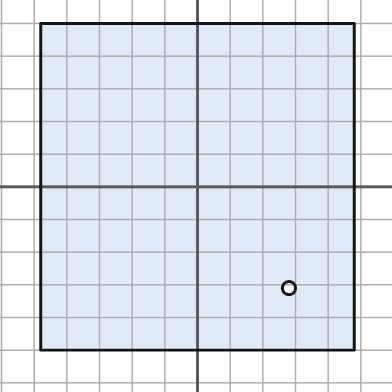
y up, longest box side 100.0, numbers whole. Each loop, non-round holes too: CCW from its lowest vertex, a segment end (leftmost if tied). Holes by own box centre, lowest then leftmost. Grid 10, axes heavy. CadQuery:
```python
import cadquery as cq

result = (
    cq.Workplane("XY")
    .moveTo(-48.0, -50.0)
    .lineTo(48.0, -50.0)
    .lineTo(48.0, 50.0)
    .lineTo(-48.0, 50.0)
    .close()
    .moveTo(28.0, -31.0)
    .circle(2.0)
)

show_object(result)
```